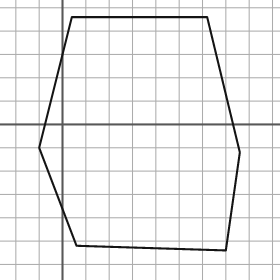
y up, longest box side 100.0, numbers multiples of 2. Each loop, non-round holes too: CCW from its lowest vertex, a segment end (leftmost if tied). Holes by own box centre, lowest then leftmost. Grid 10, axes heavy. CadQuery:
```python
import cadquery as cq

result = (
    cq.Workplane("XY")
    .moveTo(70.0, -54.0)
    .lineTo(76.0, -12.0)
    .lineTo(62.0, 46.0)
    .lineTo(4.0, 46.0)
    .lineTo(-10.0, -10.0)
    .lineTo(6.0, -52.0)
    .close()
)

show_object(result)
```